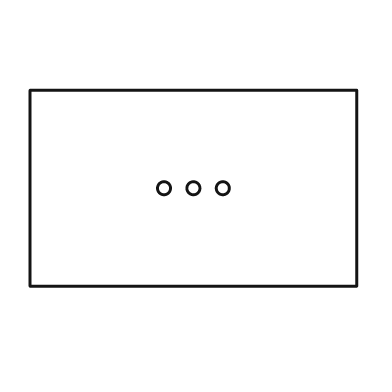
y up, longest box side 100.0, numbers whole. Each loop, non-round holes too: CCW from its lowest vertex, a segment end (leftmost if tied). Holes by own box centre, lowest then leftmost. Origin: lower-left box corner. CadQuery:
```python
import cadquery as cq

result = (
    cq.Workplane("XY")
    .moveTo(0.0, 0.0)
    .lineTo(100.0, 0.0)
    .lineTo(100.0, 60.0)
    .lineTo(0.0, 60.0)
    .close()
    .moveTo(41.0, 30.0)
    .circle(2.0)
    .moveTo(50.0, 30.0)
    .circle(2.0)
    .moveTo(59.0, 30.0)
    .circle(2.0)
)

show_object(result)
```